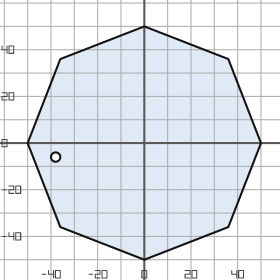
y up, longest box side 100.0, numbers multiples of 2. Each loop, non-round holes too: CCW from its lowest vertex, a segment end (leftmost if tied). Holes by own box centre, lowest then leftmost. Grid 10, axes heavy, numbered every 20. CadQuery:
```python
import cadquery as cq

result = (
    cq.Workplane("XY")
    .moveTo(0.0, -50.0)
    .lineTo(36.0, -36.0)
    .lineTo(50.0, 0.0)
    .lineTo(36.0, 36.0)
    .lineTo(0.0, 50.0)
    .lineTo(-36.0, 36.0)
    .lineTo(-50.0, 0.0)
    .lineTo(-36.0, -36.0)
    .close()
    .moveTo(-38.0, -6.0)
    .circle(2.0)
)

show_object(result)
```